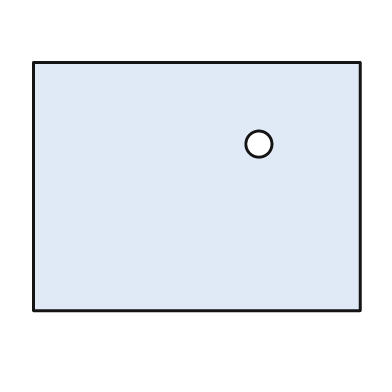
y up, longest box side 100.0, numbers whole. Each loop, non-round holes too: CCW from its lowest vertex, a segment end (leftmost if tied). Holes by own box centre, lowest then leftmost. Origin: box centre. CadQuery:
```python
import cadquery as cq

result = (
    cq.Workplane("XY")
    .moveTo(-50.0, -38.0)
    .lineTo(50.0, -38.0)
    .lineTo(50.0, 38.0)
    .lineTo(-50.0, 38.0)
    .close()
    .moveTo(19.0, 13.0)
    .circle(4.0)
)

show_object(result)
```